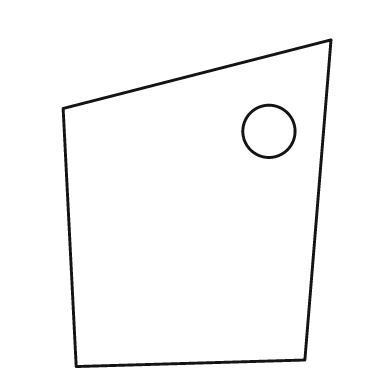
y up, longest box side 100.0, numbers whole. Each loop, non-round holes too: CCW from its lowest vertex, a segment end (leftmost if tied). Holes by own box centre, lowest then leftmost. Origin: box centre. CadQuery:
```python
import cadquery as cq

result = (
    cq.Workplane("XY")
    .moveTo(-37.0, -50.0)
    .lineTo(33.0, -48.0)
    .lineTo(41.0, 50.0)
    .lineTo(-41.0, 29.0)
    .close()
    .moveTo(22.0, 22.0)
    .circle(8.0)
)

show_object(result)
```